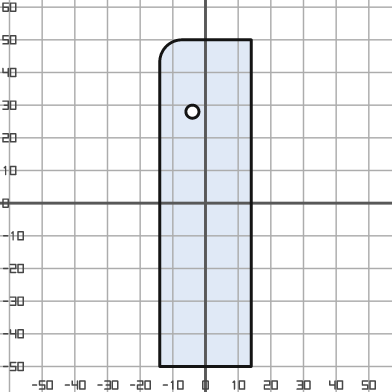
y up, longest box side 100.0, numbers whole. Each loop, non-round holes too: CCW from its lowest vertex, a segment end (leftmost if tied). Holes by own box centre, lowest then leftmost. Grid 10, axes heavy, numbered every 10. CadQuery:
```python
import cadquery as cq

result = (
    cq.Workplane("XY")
    .moveTo(-14.0, -50.0)
    .lineTo(14.0, -50.0)
    .lineTo(14.0, 50.0)
    .lineTo(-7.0, 50.0)
    .threePointArc((-12.0, 48.0), (-14.0, 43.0))
    .close()
    .moveTo(-4.0, 28.0)
    .circle(2.0)
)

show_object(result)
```